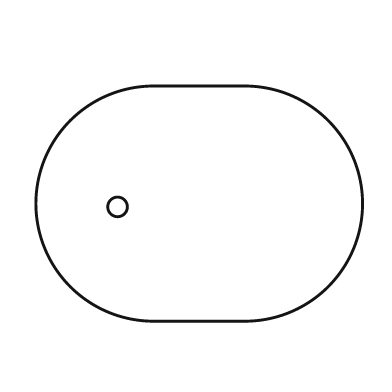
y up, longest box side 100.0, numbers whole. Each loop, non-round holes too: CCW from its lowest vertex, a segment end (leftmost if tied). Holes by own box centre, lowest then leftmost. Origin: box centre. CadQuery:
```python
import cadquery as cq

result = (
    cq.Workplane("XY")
    .moveTo(-14.0, -36.0)
    .lineTo(14.0, -36.0)
    .threePointArc((50.0, 0.0), (14.0, 36.0))
    .lineTo(-14.0, 36.0)
    .threePointArc((-50.0, 0.0), (-14.0, -36.0))
    .close()
    .moveTo(-25.0, -1.0)
    .circle(3.0)
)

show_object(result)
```